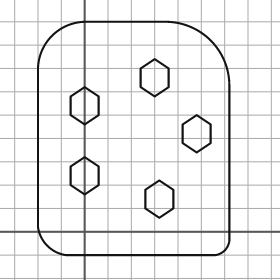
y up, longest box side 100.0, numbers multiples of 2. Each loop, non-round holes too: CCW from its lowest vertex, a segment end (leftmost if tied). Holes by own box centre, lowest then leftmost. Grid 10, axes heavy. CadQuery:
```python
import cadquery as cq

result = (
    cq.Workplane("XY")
    .moveTo(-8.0, -10.0)
    .lineTo(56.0, -10.0)
    .threePointArc((60.0, -8.0), (62.0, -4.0))
    .lineTo(62.0, 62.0)
    .threePointArc((54.0, 82.0), (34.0, 90.0))
    .lineTo(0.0, 90.0)
    .threePointArc((-14.0, 84.0), (-20.0, 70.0))
    .lineTo(-20.0, 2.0)
    .threePointArc((-16.0, -6.0), (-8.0, -10.0))
    .close()
    .moveTo(32.0, 6.0)
    .lineTo(38.0, 10.0)
    .lineTo(38.0, 18.0)
    .lineTo(32.0, 22.0)
    .lineTo(26.0, 18.0)
    .lineTo(26.0, 10.0)
    .close()
    .moveTo(0.0, 16.0)
    .lineTo(6.0, 20.0)
    .lineTo(6.0, 28.0)
    .lineTo(0.0, 32.0)
    .lineTo(-6.0, 28.0)
    .lineTo(-6.0, 20.0)
    .close()
    .moveTo(48.0, 34.0)
    .lineTo(54.0, 38.0)
    .lineTo(54.0, 46.0)
    .lineTo(48.0, 50.0)
    .lineTo(42.0, 46.0)
    .lineTo(42.0, 38.0)
    .close()
    .moveTo(0.0, 46.0)
    .lineTo(6.0, 50.0)
    .lineTo(6.0, 58.0)
    .lineTo(0.0, 62.0)
    .lineTo(-6.0, 58.0)
    .lineTo(-6.0, 50.0)
    .close()
    .moveTo(30.0, 58.0)
    .lineTo(36.0, 62.0)
    .lineTo(36.0, 70.0)
    .lineTo(30.0, 74.0)
    .lineTo(24.0, 70.0)
    .lineTo(24.0, 62.0)
    .close()
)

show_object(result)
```